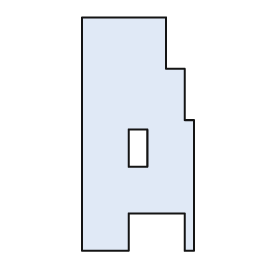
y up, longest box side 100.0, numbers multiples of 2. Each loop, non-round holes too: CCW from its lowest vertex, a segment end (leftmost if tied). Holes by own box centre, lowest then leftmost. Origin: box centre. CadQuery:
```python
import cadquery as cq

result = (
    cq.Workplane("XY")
    .moveTo(-24.0, -50.0)
    .lineTo(-4.0, -50.0)
    .lineTo(-4.0, -34.0)
    .lineTo(20.0, -34.0)
    .lineTo(20.0, -50.0)
    .lineTo(24.0, -50.0)
    .lineTo(24.0, 6.0)
    .lineTo(20.0, 6.0)
    .lineTo(20.0, 28.0)
    .lineTo(12.0, 28.0)
    .lineTo(12.0, 50.0)
    .lineTo(-24.0, 50.0)
    .close()
    .moveTo(-4.0, -14.0)
    .lineTo(4.0, -14.0)
    .lineTo(4.0, 2.0)
    .lineTo(-4.0, 2.0)
    .close()
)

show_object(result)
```